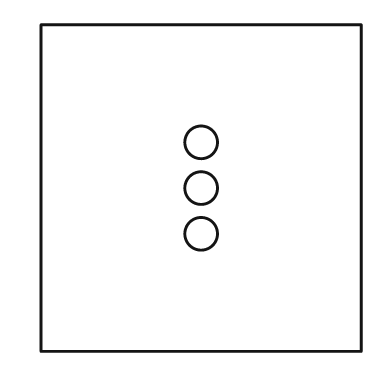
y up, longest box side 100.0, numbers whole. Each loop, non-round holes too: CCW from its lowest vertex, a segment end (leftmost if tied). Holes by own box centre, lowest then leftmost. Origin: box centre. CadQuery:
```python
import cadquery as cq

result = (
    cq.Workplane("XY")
    .moveTo(-49.0, -50.0)
    .lineTo(49.0, -50.0)
    .lineTo(49.0, 50.0)
    .lineTo(-49.0, 50.0)
    .close()
    .moveTo(0.0, -14.0)
    .circle(5.0)
    .moveTo(0.0, 0.0)
    .circle(5.0)
    .moveTo(0.0, 14.0)
    .circle(5.0)
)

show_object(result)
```